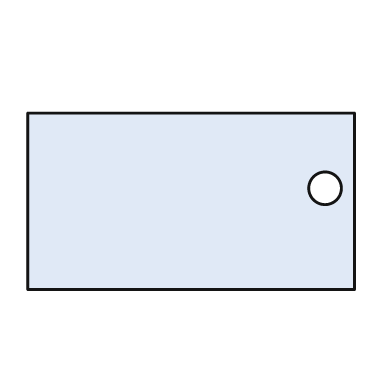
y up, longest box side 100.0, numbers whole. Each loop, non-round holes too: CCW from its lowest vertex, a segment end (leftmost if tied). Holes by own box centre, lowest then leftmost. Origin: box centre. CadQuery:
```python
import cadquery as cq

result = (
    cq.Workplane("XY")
    .moveTo(-50.0, -27.0)
    .lineTo(50.0, -27.0)
    .lineTo(50.0, 27.0)
    .lineTo(-50.0, 27.0)
    .close()
    .moveTo(41.0, 4.0)
    .circle(5.0)
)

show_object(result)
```